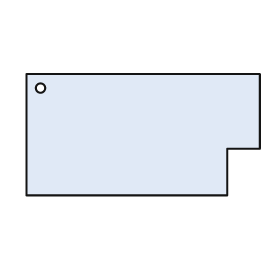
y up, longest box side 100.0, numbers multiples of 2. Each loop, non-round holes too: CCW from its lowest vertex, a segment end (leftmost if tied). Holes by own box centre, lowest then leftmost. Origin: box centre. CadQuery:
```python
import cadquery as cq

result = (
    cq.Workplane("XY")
    .moveTo(-50.0, -26.0)
    .lineTo(36.0, -26.0)
    .lineTo(36.0, -6.0)
    .lineTo(50.0, -6.0)
    .lineTo(50.0, 26.0)
    .lineTo(-50.0, 26.0)
    .close()
    .moveTo(-44.0, 20.0)
    .circle(2.0)
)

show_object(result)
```